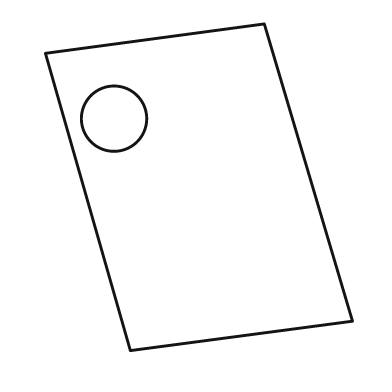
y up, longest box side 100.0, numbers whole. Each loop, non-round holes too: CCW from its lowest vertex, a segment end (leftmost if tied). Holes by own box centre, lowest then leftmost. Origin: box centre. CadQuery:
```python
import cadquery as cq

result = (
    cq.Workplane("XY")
    .moveTo(-21.0, -50.0)
    .lineTo(47.0, -41.0)
    .lineTo(20.0, 50.0)
    .lineTo(-47.0, 41.0)
    .close()
    .moveTo(-26.0, 21.0)
    .circle(10.0)
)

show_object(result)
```